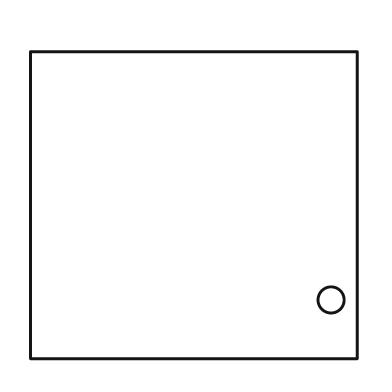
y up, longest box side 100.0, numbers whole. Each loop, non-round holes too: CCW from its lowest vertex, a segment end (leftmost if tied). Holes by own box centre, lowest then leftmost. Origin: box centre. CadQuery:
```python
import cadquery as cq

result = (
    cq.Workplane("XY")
    .moveTo(-50.0, -47.0)
    .lineTo(50.0, -47.0)
    .lineTo(50.0, 47.0)
    .lineTo(-50.0, 47.0)
    .close()
    .moveTo(42.0, -29.0)
    .circle(4.0)
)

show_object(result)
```